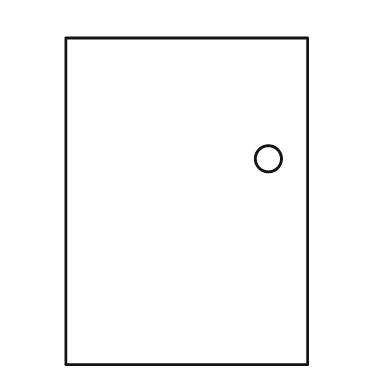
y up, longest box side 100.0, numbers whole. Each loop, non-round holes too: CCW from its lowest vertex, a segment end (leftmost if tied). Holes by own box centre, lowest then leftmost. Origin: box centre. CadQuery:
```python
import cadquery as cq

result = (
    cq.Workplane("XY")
    .moveTo(-37.0, -50.0)
    .lineTo(37.0, -50.0)
    .lineTo(37.0, 50.0)
    .lineTo(-37.0, 50.0)
    .close()
    .moveTo(25.0, 13.0)
    .circle(4.0)
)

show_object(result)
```